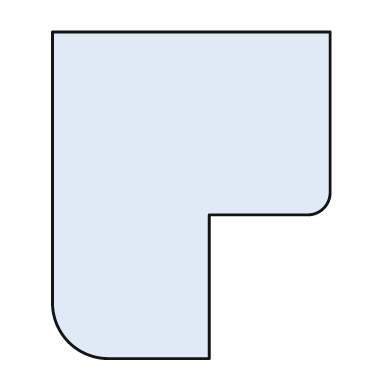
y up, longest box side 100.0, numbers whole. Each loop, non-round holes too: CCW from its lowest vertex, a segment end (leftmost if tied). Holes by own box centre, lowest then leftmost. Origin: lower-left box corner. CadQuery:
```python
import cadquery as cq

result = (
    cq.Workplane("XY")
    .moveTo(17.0, 0.0)
    .lineTo(48.0, 0.0)
    .lineTo(48.0, 44.0)
    .lineTo(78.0, 44.0)
    .threePointArc((83.0, 46.0), (85.0, 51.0))
    .lineTo(85.0, 100.0)
    .lineTo(0.0, 100.0)
    .lineTo(0.0, 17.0)
    .threePointArc((5.0, 5.0), (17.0, 0.0))
    .close()
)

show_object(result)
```